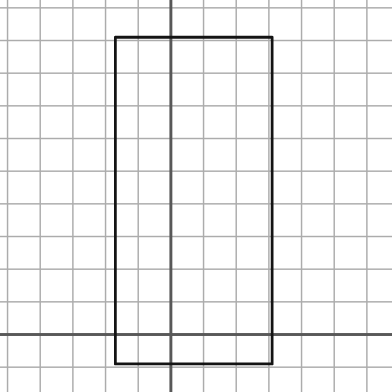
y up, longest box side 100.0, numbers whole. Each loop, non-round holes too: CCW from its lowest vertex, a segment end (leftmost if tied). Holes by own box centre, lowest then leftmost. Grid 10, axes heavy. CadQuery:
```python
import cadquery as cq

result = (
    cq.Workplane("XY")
    .moveTo(-17.0, -9.0)
    .lineTo(31.0, -9.0)
    .lineTo(31.0, 91.0)
    .lineTo(-17.0, 91.0)
    .close()
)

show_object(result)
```